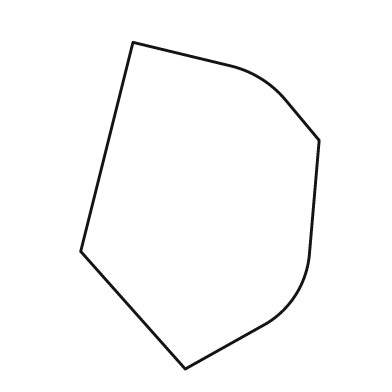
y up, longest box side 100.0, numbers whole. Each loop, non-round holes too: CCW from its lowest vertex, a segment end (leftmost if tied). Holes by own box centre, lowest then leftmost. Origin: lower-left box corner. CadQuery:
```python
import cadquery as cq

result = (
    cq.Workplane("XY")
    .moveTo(32.0, 0.0)
    .lineTo(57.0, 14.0)
    .threePointArc((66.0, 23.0), (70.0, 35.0))
    .lineTo(73.0, 70.0)
    .lineTo(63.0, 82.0)
    .threePointArc((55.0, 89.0), (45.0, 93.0))
    .lineTo(16.0, 100.0)
    .lineTo(0.0, 36.0)
    .close()
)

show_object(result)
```